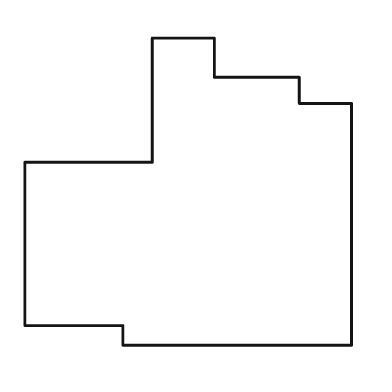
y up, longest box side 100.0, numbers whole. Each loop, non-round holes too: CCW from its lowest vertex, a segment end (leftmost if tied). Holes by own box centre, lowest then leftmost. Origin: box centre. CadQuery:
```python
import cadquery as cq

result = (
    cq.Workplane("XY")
    .moveTo(-20.0, -47.0)
    .lineTo(50.0, -47.0)
    .lineTo(50.0, 27.0)
    .lineTo(34.0, 27.0)
    .lineTo(34.0, 35.0)
    .lineTo(8.0, 35.0)
    .lineTo(8.0, 47.0)
    .lineTo(-11.0, 47.0)
    .lineTo(-11.0, 9.0)
    .lineTo(-50.0, 9.0)
    .lineTo(-50.0, -41.0)
    .lineTo(-20.0, -41.0)
    .close()
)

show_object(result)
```